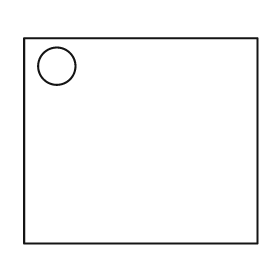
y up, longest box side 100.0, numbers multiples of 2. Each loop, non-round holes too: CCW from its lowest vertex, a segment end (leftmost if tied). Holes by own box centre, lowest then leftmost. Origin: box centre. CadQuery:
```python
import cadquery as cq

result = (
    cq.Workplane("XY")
    .moveTo(-50.0, -44.0)
    .lineTo(50.0, -44.0)
    .lineTo(50.0, 44.0)
    .lineTo(-50.0, 44.0)
    .close()
    .moveTo(-36.0, 32.0)
    .circle(8.0)
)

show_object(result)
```